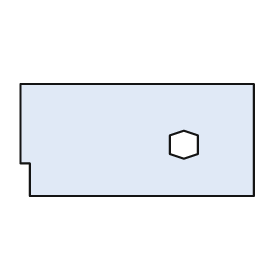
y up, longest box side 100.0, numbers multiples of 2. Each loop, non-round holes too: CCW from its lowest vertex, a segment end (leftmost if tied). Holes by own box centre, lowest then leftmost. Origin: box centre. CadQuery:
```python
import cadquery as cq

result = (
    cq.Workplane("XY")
    .moveTo(-46.0, -24.0)
    .lineTo(50.0, -24.0)
    .lineTo(50.0, 24.0)
    .lineTo(-50.0, 24.0)
    .lineTo(-50.0, -10.0)
    .lineTo(-46.0, -10.0)
    .close()
    .moveTo(20.0, -8.0)
    .lineTo(26.0, -6.0)
    .lineTo(26.0, 2.0)
    .lineTo(20.0, 4.0)
    .lineTo(14.0, 2.0)
    .lineTo(14.0, -6.0)
    .close()
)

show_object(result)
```